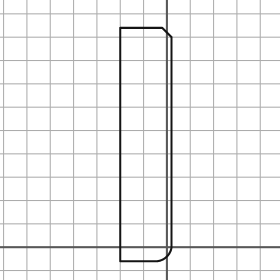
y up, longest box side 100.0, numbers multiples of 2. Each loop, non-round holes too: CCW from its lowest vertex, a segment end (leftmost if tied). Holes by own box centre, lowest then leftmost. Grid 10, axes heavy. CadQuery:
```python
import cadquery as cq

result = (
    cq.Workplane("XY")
    .moveTo(-20.0, -6.0)
    .lineTo(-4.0, -6.0)
    .threePointArc((0.0, -4.0), (2.0, 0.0))
    .lineTo(2.0, 90.0)
    .lineTo(-2.0, 94.0)
    .lineTo(-20.0, 94.0)
    .close()
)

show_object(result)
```